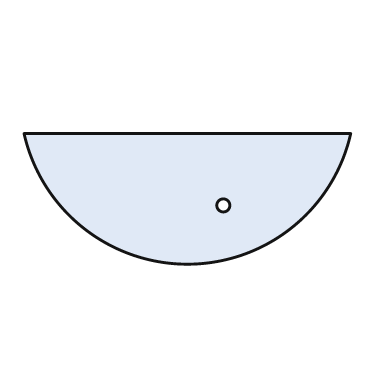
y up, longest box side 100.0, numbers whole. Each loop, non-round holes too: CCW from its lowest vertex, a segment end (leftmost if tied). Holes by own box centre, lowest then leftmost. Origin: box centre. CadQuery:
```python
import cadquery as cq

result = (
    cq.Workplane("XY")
    .moveTo(-50.0, 20.0)
    .threePointArc((0.0, -20.0), (50.0, 20.0))
    .close()
    .moveTo(11.0, -2.0)
    .circle(2.0)
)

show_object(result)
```